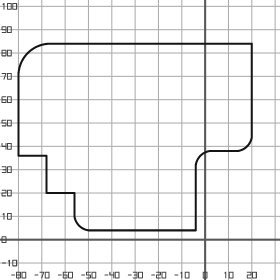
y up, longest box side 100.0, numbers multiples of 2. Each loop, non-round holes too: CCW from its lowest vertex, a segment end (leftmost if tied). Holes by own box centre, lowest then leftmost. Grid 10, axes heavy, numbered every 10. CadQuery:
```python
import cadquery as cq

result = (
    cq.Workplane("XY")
    .moveTo(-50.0, 4.0)
    .lineTo(-4.0, 4.0)
    .lineTo(-4.0, 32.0)
    .threePointArc((-2.0, 36.0), (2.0, 38.0))
    .lineTo(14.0, 38.0)
    .threePointArc((18.0, 40.0), (20.0, 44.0))
    .lineTo(20.0, 84.0)
    .lineTo(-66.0, 84.0)
    .threePointArc((-76.0, 80.0), (-80.0, 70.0))
    .lineTo(-80.0, 36.0)
    .lineTo(-68.0, 36.0)
    .lineTo(-68.0, 20.0)
    .lineTo(-56.0, 20.0)
    .lineTo(-56.0, 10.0)
    .threePointArc((-54.0, 6.0), (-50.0, 4.0))
    .close()
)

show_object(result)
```